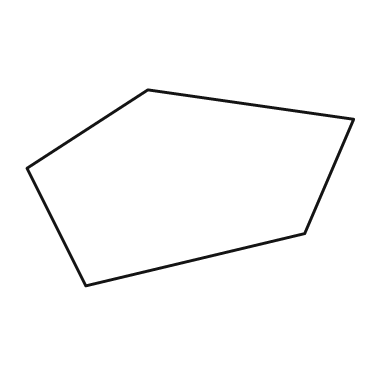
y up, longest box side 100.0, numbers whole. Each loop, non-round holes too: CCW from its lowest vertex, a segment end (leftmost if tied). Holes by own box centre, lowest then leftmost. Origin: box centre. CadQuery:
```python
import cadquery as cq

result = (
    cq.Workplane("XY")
    .moveTo(-32.0, -30.0)
    .lineTo(35.0, -14.0)
    .lineTo(50.0, 21.0)
    .lineTo(-13.0, 30.0)
    .lineTo(-50.0, 6.0)
    .close()
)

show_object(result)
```